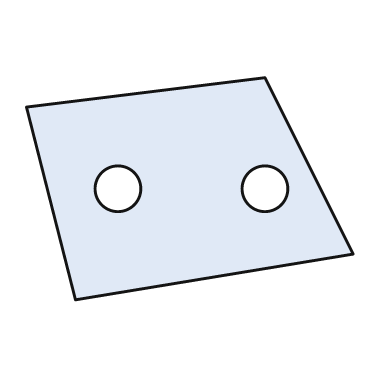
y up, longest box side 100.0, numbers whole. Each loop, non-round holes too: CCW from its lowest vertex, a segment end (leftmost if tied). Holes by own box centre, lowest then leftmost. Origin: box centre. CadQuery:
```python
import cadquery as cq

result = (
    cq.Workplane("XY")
    .moveTo(-35.0, -34.0)
    .lineTo(50.0, -20.0)
    .lineTo(23.0, 34.0)
    .lineTo(-50.0, 25.0)
    .close()
    .moveTo(-22.0, 0.0)
    .circle(7.0)
    .moveTo(23.0, 0.0)
    .circle(7.0)
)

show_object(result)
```